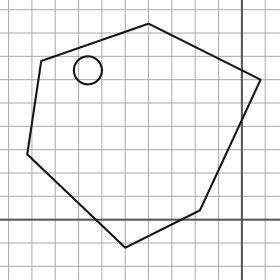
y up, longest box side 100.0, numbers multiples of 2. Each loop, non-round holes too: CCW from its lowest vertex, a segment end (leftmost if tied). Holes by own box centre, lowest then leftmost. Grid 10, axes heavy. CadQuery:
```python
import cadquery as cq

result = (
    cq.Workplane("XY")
    .moveTo(-50.0, -12.0)
    .lineTo(-18.0, 4.0)
    .lineTo(8.0, 60.0)
    .lineTo(-40.0, 84.0)
    .lineTo(-86.0, 68.0)
    .lineTo(-92.0, 28.0)
    .close()
    .moveTo(-66.0, 64.0)
    .circle(6.0)
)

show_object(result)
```